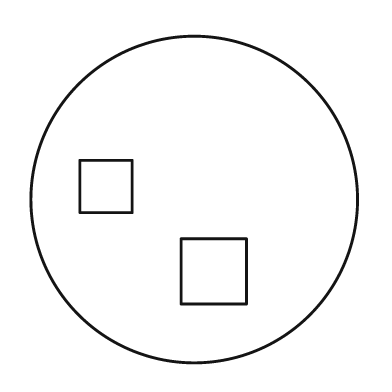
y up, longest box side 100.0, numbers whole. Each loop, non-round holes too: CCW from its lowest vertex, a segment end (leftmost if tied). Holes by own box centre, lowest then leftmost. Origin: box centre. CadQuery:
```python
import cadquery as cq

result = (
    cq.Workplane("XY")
    .moveTo(0.0, 0.0)
    .circle(50.0)
    .moveTo(-4.0, -32.0)
    .lineTo(16.0, -32.0)
    .lineTo(16.0, -12.0)
    .lineTo(-4.0, -12.0)
    .close()
    .moveTo(-35.0, -4.0)
    .lineTo(-19.0, -4.0)
    .lineTo(-19.0, 12.0)
    .lineTo(-35.0, 12.0)
    .close()
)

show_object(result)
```